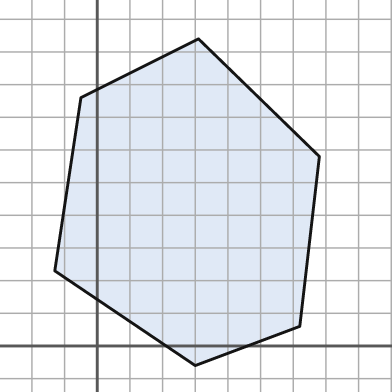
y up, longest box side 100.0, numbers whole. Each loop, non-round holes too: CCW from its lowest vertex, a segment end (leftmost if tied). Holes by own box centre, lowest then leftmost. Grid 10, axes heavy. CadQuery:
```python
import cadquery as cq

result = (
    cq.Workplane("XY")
    .moveTo(30.0, -6.0)
    .lineTo(62.0, 6.0)
    .lineTo(68.0, 58.0)
    .lineTo(31.0, 94.0)
    .lineTo(-5.0, 76.0)
    .lineTo(-13.0, 23.0)
    .close()
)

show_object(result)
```